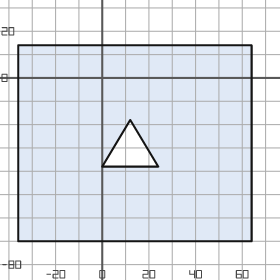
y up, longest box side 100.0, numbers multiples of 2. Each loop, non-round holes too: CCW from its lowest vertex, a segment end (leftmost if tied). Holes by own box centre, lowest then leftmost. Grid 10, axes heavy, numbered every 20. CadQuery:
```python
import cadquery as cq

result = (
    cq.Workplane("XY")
    .moveTo(-36.0, -70.0)
    .lineTo(64.0, -70.0)
    .lineTo(64.0, 14.0)
    .lineTo(-36.0, 14.0)
    .close()
    .moveTo(0.0, -38.0)
    .lineTo(24.0, -38.0)
    .lineTo(12.0, -18.0)
    .close()
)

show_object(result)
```